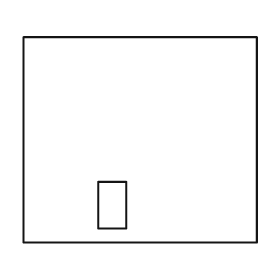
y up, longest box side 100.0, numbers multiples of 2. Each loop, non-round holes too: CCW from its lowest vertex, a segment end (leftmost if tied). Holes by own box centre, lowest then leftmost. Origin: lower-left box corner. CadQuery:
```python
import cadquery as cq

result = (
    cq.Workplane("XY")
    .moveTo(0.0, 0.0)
    .lineTo(100.0, 0.0)
    .lineTo(100.0, 88.0)
    .lineTo(0.0, 88.0)
    .close()
    .moveTo(32.0, 6.0)
    .lineTo(44.0, 6.0)
    .lineTo(44.0, 26.0)
    .lineTo(32.0, 26.0)
    .close()
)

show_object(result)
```